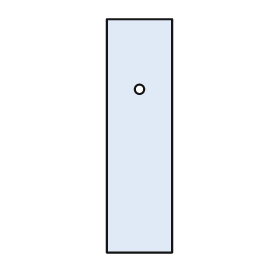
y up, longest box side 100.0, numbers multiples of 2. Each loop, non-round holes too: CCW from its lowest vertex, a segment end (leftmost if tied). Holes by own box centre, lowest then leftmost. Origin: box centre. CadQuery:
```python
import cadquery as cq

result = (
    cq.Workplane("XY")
    .moveTo(-14.0, -50.0)
    .lineTo(14.0, -50.0)
    .lineTo(14.0, 50.0)
    .lineTo(-14.0, 50.0)
    .close()
    .moveTo(0.0, 20.0)
    .circle(2.0)
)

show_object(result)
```